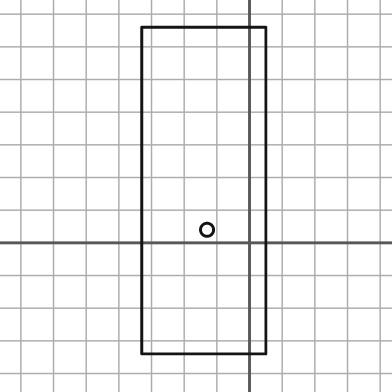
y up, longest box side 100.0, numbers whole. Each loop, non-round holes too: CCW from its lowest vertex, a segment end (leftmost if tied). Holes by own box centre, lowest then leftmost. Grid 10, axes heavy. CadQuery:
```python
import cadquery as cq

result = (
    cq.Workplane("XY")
    .moveTo(-33.0, -34.0)
    .lineTo(5.0, -34.0)
    .lineTo(5.0, 66.0)
    .lineTo(-33.0, 66.0)
    .close()
    .moveTo(-13.0, 4.0)
    .circle(2.0)
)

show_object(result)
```